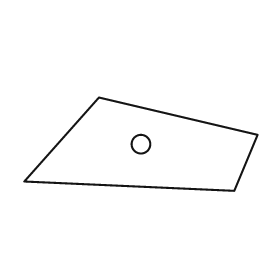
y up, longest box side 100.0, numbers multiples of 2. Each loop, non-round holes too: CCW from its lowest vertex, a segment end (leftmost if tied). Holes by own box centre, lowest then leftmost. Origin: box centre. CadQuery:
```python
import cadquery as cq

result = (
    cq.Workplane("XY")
    .moveTo(40.0, -20.0)
    .lineTo(50.0, 4.0)
    .lineTo(-18.0, 20.0)
    .lineTo(-50.0, -16.0)
    .close()
    .moveTo(0.0, 0.0)
    .circle(4.0)
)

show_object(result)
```